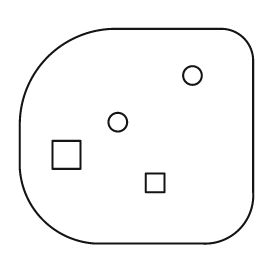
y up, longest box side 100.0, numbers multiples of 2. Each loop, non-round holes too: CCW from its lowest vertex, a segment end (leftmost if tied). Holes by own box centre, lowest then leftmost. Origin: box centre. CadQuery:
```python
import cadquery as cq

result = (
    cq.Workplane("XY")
    .moveTo(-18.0, -46.0)
    .lineTo(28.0, -46.0)
    .threePointArc((44.0, -40.0), (50.0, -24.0))
    .lineTo(50.0, 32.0)
    .threePointArc((46.0, 42.0), (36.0, 46.0))
    .lineTo(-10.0, 46.0)
    .threePointArc((-38.0, 34.0), (-50.0, 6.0))
    .lineTo(-50.0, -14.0)
    .threePointArc((-40.0, -36.0), (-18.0, -46.0))
    .close()
    .moveTo(4.0, -24.0)
    .lineTo(12.0, -24.0)
    .lineTo(12.0, -16.0)
    .lineTo(4.0, -16.0)
    .close()
    .moveTo(-36.0, -14.0)
    .lineTo(-24.0, -14.0)
    .lineTo(-24.0, -2.0)
    .lineTo(-36.0, -2.0)
    .close()
    .moveTo(-8.0, 6.0)
    .circle(4.0)
    .moveTo(24.0, 26.0)
    .circle(4.0)
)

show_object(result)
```